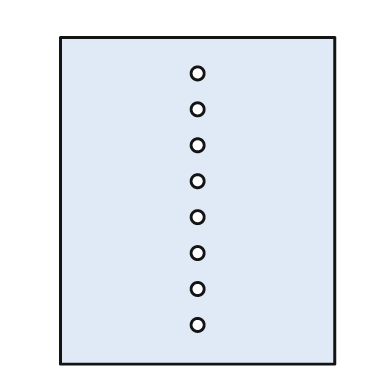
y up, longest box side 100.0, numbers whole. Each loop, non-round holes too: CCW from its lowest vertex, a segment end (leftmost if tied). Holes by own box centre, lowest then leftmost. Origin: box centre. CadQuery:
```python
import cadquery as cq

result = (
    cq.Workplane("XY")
    .moveTo(-42.0, -50.0)
    .lineTo(42.0, -50.0)
    .lineTo(42.0, 50.0)
    .lineTo(-42.0, 50.0)
    .close()
    .moveTo(0.0, -38.0)
    .circle(2.0)
    .moveTo(0.0, -27.0)
    .circle(2.0)
    .moveTo(0.0, -16.0)
    .circle(2.0)
    .moveTo(0.0, -5.0)
    .circle(2.0)
    .moveTo(0.0, 6.0)
    .circle(2.0)
    .moveTo(0.0, 17.0)
    .circle(2.0)
    .moveTo(0.0, 28.0)
    .circle(2.0)
    .moveTo(0.0, 39.0)
    .circle(2.0)
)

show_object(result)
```